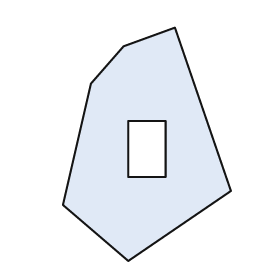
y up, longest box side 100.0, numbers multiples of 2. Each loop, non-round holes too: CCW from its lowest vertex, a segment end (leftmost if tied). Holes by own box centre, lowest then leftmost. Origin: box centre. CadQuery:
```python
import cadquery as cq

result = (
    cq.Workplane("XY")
    .moveTo(-8.0, -50.0)
    .lineTo(36.0, -20.0)
    .lineTo(12.0, 50.0)
    .lineTo(-10.0, 42.0)
    .lineTo(-24.0, 26.0)
    .lineTo(-36.0, -26.0)
    .close()
    .moveTo(-8.0, -14.0)
    .lineTo(8.0, -14.0)
    .lineTo(8.0, 10.0)
    .lineTo(-8.0, 10.0)
    .close()
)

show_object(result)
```